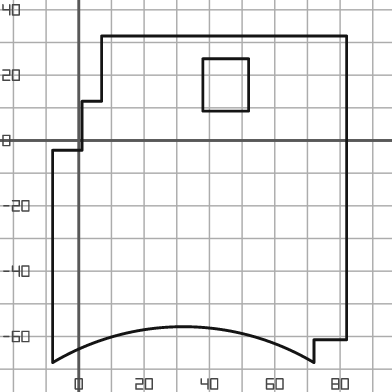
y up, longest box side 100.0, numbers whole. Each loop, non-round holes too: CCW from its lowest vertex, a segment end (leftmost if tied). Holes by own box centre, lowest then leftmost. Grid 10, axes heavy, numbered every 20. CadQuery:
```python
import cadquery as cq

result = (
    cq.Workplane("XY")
    .moveTo(-8.0, -68.0)
    .threePointArc((32.0, -57.0), (72.0, -68.0))
    .lineTo(72.0, -61.0)
    .lineTo(82.0, -61.0)
    .lineTo(82.0, 32.0)
    .lineTo(7.0, 32.0)
    .lineTo(7.0, 12.0)
    .lineTo(1.0, 12.0)
    .lineTo(1.0, -3.0)
    .lineTo(-8.0, -3.0)
    .close()
    .moveTo(38.0, 9.0)
    .lineTo(52.0, 9.0)
    .lineTo(52.0, 25.0)
    .lineTo(38.0, 25.0)
    .close()
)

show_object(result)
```